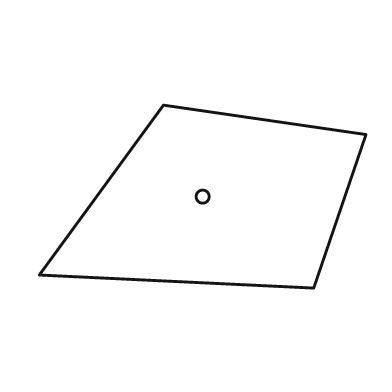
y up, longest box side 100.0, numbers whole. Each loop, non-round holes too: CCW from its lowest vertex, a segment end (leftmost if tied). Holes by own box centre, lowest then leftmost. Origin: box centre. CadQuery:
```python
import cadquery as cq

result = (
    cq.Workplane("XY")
    .moveTo(34.0, -28.0)
    .lineTo(50.0, 19.0)
    .lineTo(-12.0, 28.0)
    .lineTo(-50.0, -24.0)
    .close()
    .moveTo(0.0, 0.0)
    .circle(2.0)
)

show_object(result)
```